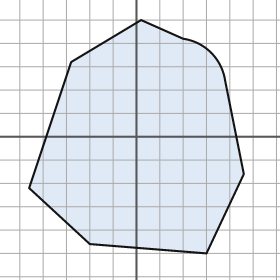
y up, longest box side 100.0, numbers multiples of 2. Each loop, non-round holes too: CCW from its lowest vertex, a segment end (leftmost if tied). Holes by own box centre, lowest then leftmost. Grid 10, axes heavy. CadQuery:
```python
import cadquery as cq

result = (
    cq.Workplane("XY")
    .moveTo(30.0, -50.0)
    .lineTo(46.0, -16.0)
    .lineTo(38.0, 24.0)
    .threePointArc((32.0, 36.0), (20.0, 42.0))
    .lineTo(2.0, 50.0)
    .lineTo(-28.0, 32.0)
    .lineTo(-46.0, -22.0)
    .lineTo(-20.0, -46.0)
    .close()
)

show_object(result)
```